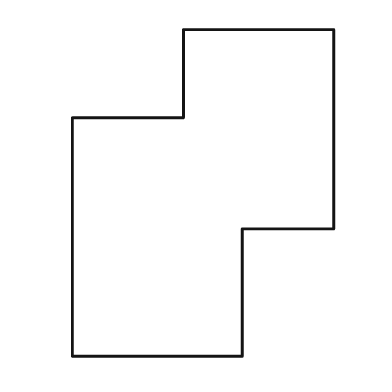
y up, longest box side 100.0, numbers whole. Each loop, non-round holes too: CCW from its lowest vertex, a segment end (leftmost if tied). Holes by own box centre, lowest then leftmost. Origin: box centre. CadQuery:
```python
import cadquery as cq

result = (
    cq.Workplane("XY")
    .moveTo(-40.0, -50.0)
    .lineTo(12.0, -50.0)
    .lineTo(12.0, -11.0)
    .lineTo(40.0, -11.0)
    .lineTo(40.0, 50.0)
    .lineTo(-6.0, 50.0)
    .lineTo(-6.0, 23.0)
    .lineTo(-40.0, 23.0)
    .close()
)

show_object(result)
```